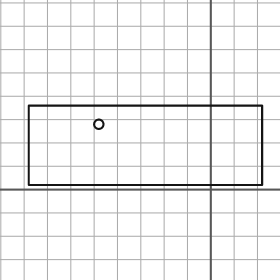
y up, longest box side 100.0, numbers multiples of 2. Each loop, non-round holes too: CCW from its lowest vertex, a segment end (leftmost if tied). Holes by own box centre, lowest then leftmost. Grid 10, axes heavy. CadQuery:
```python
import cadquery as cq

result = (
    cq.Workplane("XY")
    .moveTo(-78.0, 2.0)
    .lineTo(22.0, 2.0)
    .lineTo(22.0, 36.0)
    .lineTo(-78.0, 36.0)
    .close()
    .moveTo(-48.0, 28.0)
    .circle(2.0)
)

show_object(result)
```